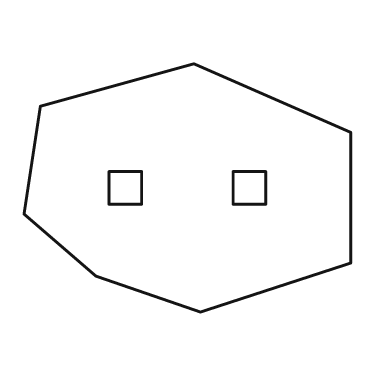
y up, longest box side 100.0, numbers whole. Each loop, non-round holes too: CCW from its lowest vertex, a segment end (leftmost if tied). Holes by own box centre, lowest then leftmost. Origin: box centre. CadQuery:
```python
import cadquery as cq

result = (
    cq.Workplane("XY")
    .moveTo(4.0, -38.0)
    .lineTo(50.0, -23.0)
    .lineTo(50.0, 17.0)
    .lineTo(2.0, 38.0)
    .lineTo(-45.0, 25.0)
    .lineTo(-50.0, -8.0)
    .lineTo(-28.0, -27.0)
    .close()
    .moveTo(-24.0, -5.0)
    .lineTo(-14.0, -5.0)
    .lineTo(-14.0, 5.0)
    .lineTo(-24.0, 5.0)
    .close()
    .moveTo(14.0, -5.0)
    .lineTo(24.0, -5.0)
    .lineTo(24.0, 5.0)
    .lineTo(14.0, 5.0)
    .close()
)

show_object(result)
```